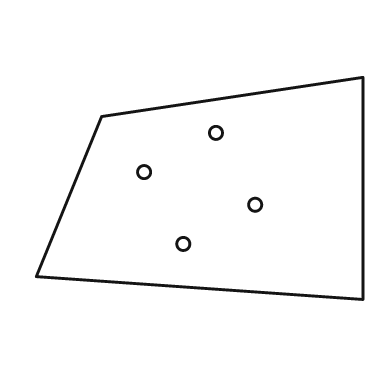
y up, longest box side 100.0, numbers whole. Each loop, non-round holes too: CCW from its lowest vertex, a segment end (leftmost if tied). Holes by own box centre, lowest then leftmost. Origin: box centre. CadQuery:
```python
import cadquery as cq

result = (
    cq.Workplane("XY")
    .moveTo(50.0, -34.0)
    .lineTo(50.0, 34.0)
    .lineTo(-30.0, 22.0)
    .lineTo(-50.0, -27.0)
    .close()
    .moveTo(-5.0, -17.0)
    .circle(2.0)
    .moveTo(17.0, -5.0)
    .circle(2.0)
    .moveTo(-17.0, 5.0)
    .circle(2.0)
    .moveTo(5.0, 17.0)
    .circle(2.0)
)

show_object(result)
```